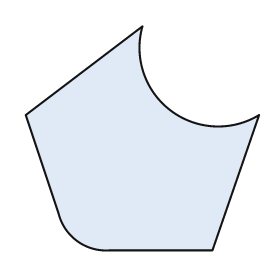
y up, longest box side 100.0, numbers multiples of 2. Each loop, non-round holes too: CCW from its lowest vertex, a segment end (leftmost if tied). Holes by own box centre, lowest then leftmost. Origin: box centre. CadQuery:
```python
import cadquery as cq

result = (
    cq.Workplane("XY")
    .moveTo(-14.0, -48.0)
    .lineTo(30.0, -48.0)
    .lineTo(50.0, 10.0)
    .threePointArc((12.0, 12.0), (0.0, 48.0))
    .lineTo(-50.0, 10.0)
    .lineTo(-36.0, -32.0)
    .threePointArc((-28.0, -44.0), (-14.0, -48.0))
    .close()
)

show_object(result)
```